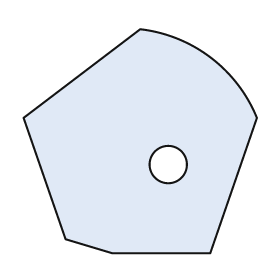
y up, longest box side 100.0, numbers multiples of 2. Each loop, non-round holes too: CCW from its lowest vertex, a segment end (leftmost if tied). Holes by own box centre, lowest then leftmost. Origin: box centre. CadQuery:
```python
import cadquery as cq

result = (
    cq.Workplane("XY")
    .moveTo(-12.0, -48.0)
    .lineTo(30.0, -48.0)
    .lineTo(50.0, 10.0)
    .threePointArc((30.0, 36.0), (0.0, 48.0))
    .lineTo(-50.0, 10.0)
    .lineTo(-32.0, -42.0)
    .close()
    .moveTo(12.0, -10.0)
    .circle(8.0)
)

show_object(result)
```